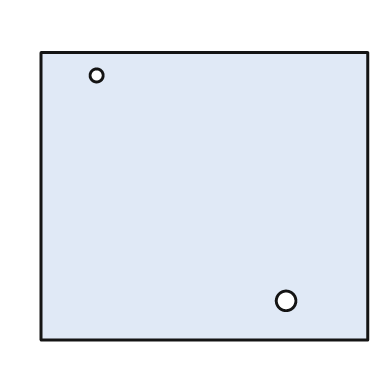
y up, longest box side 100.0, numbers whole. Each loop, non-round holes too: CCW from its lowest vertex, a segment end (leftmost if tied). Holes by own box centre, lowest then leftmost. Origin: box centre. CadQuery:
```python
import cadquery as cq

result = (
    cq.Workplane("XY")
    .moveTo(-50.0, -44.0)
    .lineTo(50.0, -44.0)
    .lineTo(50.0, 44.0)
    .lineTo(-50.0, 44.0)
    .close()
    .moveTo(25.0, -32.0)
    .circle(3.0)
    .moveTo(-33.0, 37.0)
    .circle(2.0)
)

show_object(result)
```